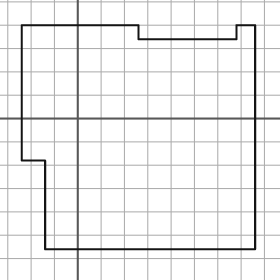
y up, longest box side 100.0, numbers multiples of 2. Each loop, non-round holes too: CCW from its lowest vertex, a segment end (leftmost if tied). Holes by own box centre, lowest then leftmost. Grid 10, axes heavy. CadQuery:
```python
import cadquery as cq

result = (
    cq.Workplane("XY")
    .moveTo(-14.0, -56.0)
    .lineTo(76.0, -56.0)
    .lineTo(76.0, 40.0)
    .lineTo(68.0, 40.0)
    .lineTo(68.0, 34.0)
    .lineTo(26.0, 34.0)
    .lineTo(26.0, 40.0)
    .lineTo(-24.0, 40.0)
    .lineTo(-24.0, -18.0)
    .lineTo(-14.0, -18.0)
    .close()
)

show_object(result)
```